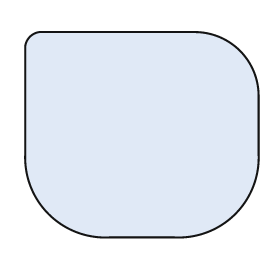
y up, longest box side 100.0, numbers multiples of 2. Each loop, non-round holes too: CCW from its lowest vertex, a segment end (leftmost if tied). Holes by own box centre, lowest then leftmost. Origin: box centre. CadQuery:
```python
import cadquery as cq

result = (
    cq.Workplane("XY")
    .moveTo(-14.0, -44.0)
    .lineTo(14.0, -44.0)
    .threePointArc((40.0, -34.0), (50.0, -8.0))
    .lineTo(50.0, 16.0)
    .threePointArc((42.0, 36.0), (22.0, 44.0))
    .lineTo(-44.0, 44.0)
    .threePointArc((-48.0, 42.0), (-50.0, 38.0))
    .lineTo(-50.0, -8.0)
    .threePointArc((-40.0, -34.0), (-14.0, -44.0))
    .close()
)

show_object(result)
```